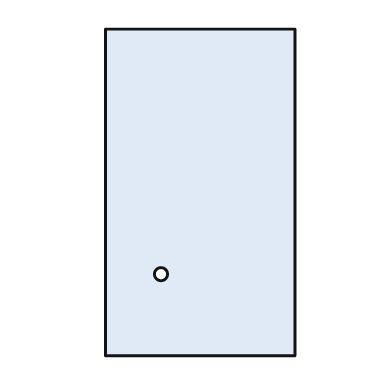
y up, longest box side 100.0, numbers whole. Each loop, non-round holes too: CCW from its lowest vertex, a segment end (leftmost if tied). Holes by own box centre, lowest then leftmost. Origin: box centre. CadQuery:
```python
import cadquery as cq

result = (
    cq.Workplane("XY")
    .moveTo(-29.0, -50.0)
    .lineTo(29.0, -50.0)
    .lineTo(29.0, 50.0)
    .lineTo(-29.0, 50.0)
    .close()
    .moveTo(-12.0, -25.0)
    .circle(2.0)
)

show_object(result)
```